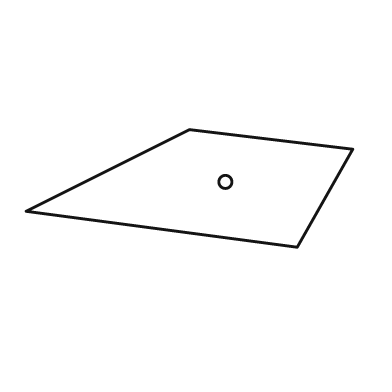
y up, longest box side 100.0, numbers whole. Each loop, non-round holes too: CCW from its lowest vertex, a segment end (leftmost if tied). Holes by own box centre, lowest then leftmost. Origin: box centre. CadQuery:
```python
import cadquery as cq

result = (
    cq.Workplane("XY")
    .moveTo(33.0, -18.0)
    .lineTo(50.0, 12.0)
    .lineTo(0.0, 18.0)
    .lineTo(-50.0, -7.0)
    .close()
    .moveTo(11.0, 2.0)
    .circle(2.0)
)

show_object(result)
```